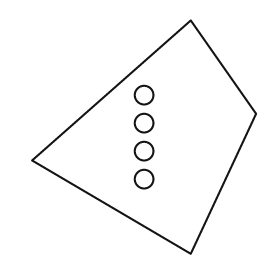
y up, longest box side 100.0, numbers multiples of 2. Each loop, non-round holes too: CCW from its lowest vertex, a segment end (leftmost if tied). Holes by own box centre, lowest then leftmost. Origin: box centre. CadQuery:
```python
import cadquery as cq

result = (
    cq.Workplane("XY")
    .moveTo(20.0, -50.0)
    .lineTo(48.0, 10.0)
    .lineTo(20.0, 50.0)
    .lineTo(-48.0, -10.0)
    .close()
    .moveTo(0.0, -18.0)
    .circle(4.0)
    .moveTo(0.0, -6.0)
    .circle(4.0)
    .moveTo(0.0, 6.0)
    .circle(4.0)
    .moveTo(0.0, 18.0)
    .circle(4.0)
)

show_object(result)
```